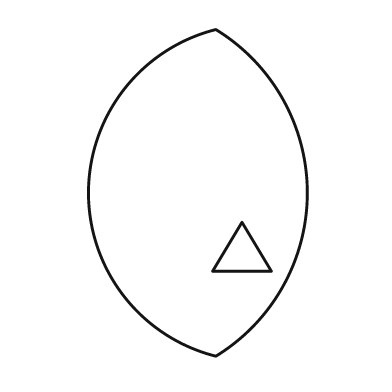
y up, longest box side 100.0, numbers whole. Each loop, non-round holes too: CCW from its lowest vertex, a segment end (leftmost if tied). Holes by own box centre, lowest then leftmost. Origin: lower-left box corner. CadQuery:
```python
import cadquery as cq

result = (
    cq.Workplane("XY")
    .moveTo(39.0, 0.0)
    .threePointArc((67.0, 50.0), (39.0, 100.0))
    .threePointArc((0.0, 50.0), (39.0, 0.0))
    .close()
    .moveTo(38.0, 26.0)
    .lineTo(56.0, 26.0)
    .lineTo(47.0, 41.0)
    .close()
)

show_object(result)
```